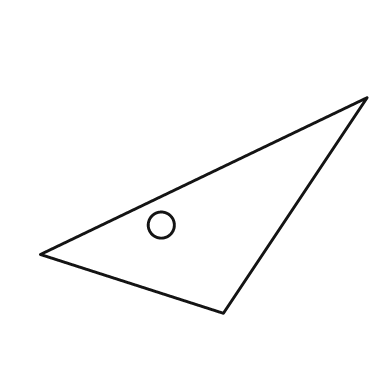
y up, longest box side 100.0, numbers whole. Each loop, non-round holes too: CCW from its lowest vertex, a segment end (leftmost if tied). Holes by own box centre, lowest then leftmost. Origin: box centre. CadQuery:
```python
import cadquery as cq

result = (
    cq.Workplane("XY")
    .moveTo(6.0, -33.0)
    .lineTo(50.0, 33.0)
    .lineTo(-50.0, -15.0)
    .close()
    .moveTo(-13.0, -6.0)
    .circle(4.0)
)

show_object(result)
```